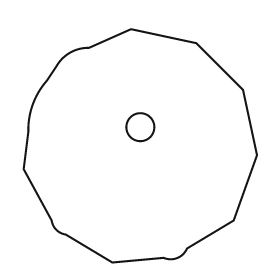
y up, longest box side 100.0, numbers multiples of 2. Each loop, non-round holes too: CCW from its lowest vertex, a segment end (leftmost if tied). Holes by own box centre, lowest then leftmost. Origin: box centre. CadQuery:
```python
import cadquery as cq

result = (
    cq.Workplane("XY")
    .moveTo(-12.0, -50.0)
    .lineTo(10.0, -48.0)
    .threePointArc((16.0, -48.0), (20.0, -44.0))
    .lineTo(40.0, -32.0)
    .lineTo(50.0, -4.0)
    .lineTo(44.0, 24.0)
    .lineTo(24.0, 44.0)
    .lineTo(-4.0, 50.0)
    .lineTo(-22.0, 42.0)
    .threePointArc((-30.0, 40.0), (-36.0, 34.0))
    .lineTo(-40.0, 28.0)
    .threePointArc((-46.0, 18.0), (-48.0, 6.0))
    .lineTo(-50.0, -10.0)
    .lineTo(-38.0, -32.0)
    .threePointArc((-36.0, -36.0), (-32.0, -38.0))
    .close()
    .moveTo(0.0, 8.0)
    .circle(6.0)
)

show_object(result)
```